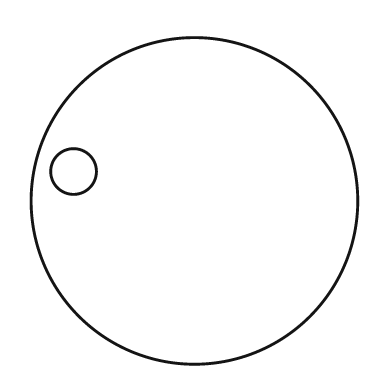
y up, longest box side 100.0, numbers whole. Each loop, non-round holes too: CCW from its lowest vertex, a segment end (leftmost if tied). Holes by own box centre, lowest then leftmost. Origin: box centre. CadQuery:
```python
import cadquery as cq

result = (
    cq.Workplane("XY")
    .moveTo(0.0, 0.0)
    .circle(50.0)
    .moveTo(-37.0, 9.0)
    .circle(7.0)
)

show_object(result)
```